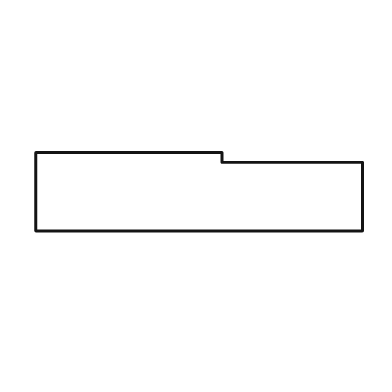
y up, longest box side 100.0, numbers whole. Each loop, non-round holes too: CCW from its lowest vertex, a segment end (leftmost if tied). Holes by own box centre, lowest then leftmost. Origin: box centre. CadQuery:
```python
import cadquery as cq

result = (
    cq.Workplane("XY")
    .moveTo(-50.0, -12.0)
    .lineTo(50.0, -12.0)
    .lineTo(50.0, 9.0)
    .lineTo(7.0, 9.0)
    .lineTo(7.0, 12.0)
    .lineTo(-50.0, 12.0)
    .close()
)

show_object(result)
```